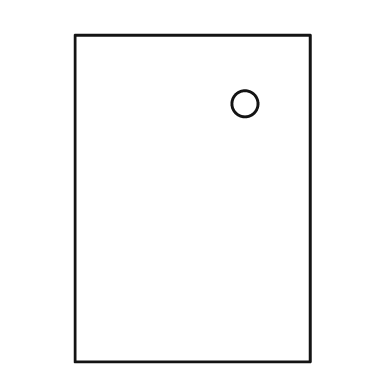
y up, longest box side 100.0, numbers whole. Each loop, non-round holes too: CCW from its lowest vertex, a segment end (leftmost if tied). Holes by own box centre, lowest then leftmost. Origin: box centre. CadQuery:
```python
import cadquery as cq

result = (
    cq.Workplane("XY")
    .moveTo(-36.0, -50.0)
    .lineTo(36.0, -50.0)
    .lineTo(36.0, 50.0)
    .lineTo(-36.0, 50.0)
    .close()
    .moveTo(16.0, 29.0)
    .circle(4.0)
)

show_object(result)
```